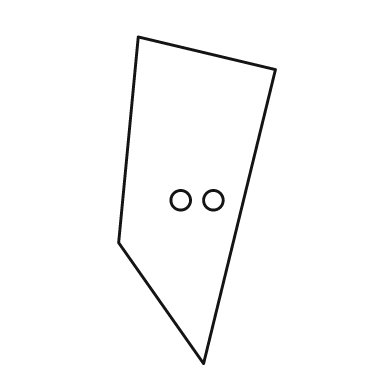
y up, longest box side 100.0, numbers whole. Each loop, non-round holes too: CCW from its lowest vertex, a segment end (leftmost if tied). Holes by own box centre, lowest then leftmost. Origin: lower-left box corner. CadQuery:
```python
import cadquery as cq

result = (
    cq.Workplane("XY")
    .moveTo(26.0, 0.0)
    .lineTo(48.0, 90.0)
    .lineTo(6.0, 100.0)
    .lineTo(0.0, 37.0)
    .close()
    .moveTo(19.0, 50.0)
    .circle(3.0)
    .moveTo(29.0, 50.0)
    .circle(3.0)
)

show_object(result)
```